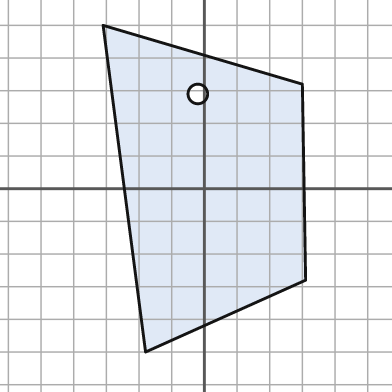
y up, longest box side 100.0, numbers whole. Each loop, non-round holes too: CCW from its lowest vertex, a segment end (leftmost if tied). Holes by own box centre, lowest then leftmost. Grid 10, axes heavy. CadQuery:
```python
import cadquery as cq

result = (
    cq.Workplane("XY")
    .moveTo(-18.0, -50.0)
    .lineTo(31.0, -28.0)
    .lineTo(30.0, 32.0)
    .lineTo(-31.0, 50.0)
    .close()
    .moveTo(-2.0, 29.0)
    .circle(3.0)
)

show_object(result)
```